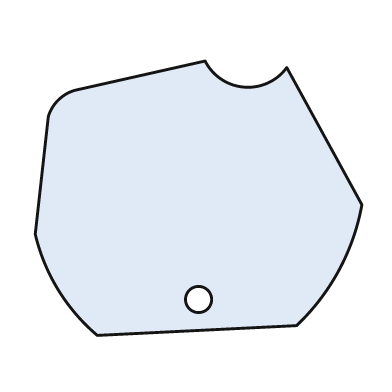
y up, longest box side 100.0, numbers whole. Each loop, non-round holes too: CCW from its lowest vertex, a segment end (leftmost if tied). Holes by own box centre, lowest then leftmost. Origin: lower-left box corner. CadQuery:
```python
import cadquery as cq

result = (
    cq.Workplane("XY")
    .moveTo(19.0, 0.0)
    .lineTo(80.0, 3.0)
    .threePointArc((93.0, 20.0), (100.0, 40.0))
    .lineTo(77.0, 82.0)
    .threePointArc((64.0, 76.0), (52.0, 84.0))
    .lineTo(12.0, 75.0)
    .threePointArc((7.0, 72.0), (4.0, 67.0))
    .lineTo(0.0, 31.0)
    .threePointArc((7.0, 14.0), (19.0, 0.0))
    .close()
    .moveTo(50.0, 11.0)
    .circle(4.0)
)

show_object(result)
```